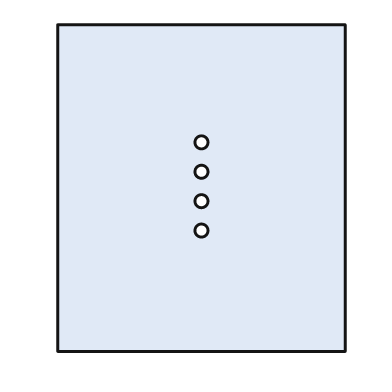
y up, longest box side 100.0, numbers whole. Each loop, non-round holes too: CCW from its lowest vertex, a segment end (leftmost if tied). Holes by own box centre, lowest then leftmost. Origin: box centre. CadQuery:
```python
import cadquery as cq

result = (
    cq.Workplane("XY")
    .moveTo(-44.0, -50.0)
    .lineTo(44.0, -50.0)
    .lineTo(44.0, 50.0)
    .lineTo(-44.0, 50.0)
    .close()
    .moveTo(0.0, -13.0)
    .circle(2.0)
    .moveTo(0.0, -4.0)
    .circle(2.0)
    .moveTo(0.0, 5.0)
    .circle(2.0)
    .moveTo(0.0, 14.0)
    .circle(2.0)
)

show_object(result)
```